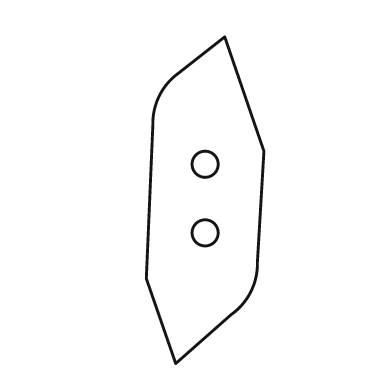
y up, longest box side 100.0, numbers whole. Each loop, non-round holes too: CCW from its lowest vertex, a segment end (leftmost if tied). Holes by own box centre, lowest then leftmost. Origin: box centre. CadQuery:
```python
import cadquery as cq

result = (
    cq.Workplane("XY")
    .moveTo(-9.0, -50.0)
    .lineTo(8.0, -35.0)
    .threePointArc((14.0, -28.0), (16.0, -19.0))
    .lineTo(18.0, 15.0)
    .lineTo(6.0, 50.0)
    .lineTo(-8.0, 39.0)
    .threePointArc((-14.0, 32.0), (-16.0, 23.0))
    .lineTo(-18.0, -24.0)
    .close()
    .moveTo(0.0, -10.0)
    .circle(4.0)
    .moveTo(0.0, 11.0)
    .circle(4.0)
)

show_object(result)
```